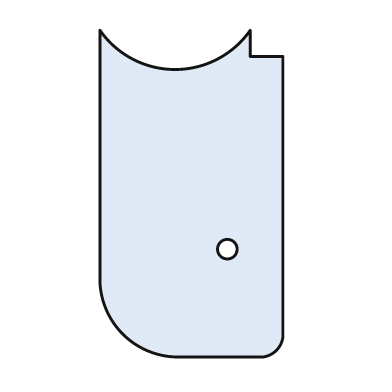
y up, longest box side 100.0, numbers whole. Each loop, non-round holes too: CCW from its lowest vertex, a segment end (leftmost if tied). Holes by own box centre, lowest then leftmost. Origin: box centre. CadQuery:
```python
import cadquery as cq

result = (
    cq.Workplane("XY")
    .moveTo(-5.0, -50.0)
    .lineTo(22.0, -50.0)
    .threePointArc((26.0, -48.0), (28.0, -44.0))
    .lineTo(28.0, 42.0)
    .lineTo(18.0, 42.0)
    .lineTo(18.0, 50.0)
    .threePointArc((-5.0, 38.0), (-28.0, 50.0))
    .lineTo(-28.0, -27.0)
    .threePointArc((-21.0, -43.0), (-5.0, -50.0))
    .close()
    .moveTo(11.0, -17.0)
    .circle(3.0)
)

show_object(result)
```